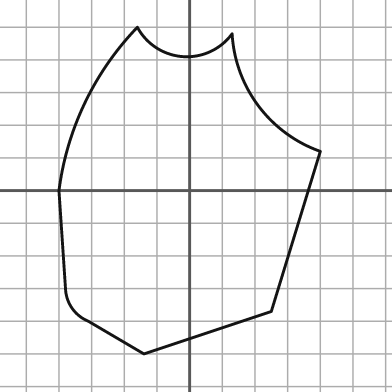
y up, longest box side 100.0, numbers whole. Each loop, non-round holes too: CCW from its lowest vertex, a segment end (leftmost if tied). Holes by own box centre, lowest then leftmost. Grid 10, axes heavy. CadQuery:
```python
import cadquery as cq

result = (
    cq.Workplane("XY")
    .moveTo(-14.0, -50.0)
    .lineTo(25.0, -37.0)
    .lineTo(40.0, 12.0)
    .threePointArc((21.0, 26.0), (13.0, 48.0))
    .threePointArc((-2.0, 41.0), (-16.0, 50.0))
    .threePointArc((-32.0, 27.0), (-40.0, 0.0))
    .lineTo(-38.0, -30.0)
    .threePointArc((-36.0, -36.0), (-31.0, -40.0))
    .close()
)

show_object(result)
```